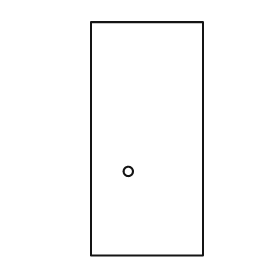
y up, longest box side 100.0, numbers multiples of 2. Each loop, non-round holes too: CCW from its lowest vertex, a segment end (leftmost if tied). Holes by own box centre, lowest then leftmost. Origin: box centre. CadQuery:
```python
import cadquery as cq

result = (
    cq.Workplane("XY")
    .moveTo(-24.0, -50.0)
    .lineTo(24.0, -50.0)
    .lineTo(24.0, 50.0)
    .lineTo(-24.0, 50.0)
    .close()
    .moveTo(-8.0, -14.0)
    .circle(2.0)
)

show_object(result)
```